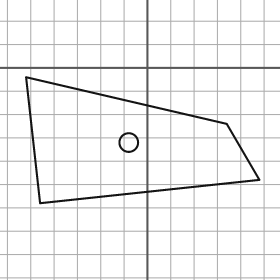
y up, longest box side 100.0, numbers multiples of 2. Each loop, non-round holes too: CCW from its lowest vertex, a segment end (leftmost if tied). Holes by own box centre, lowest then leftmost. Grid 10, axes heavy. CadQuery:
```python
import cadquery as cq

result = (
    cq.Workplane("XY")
    .moveTo(-46.0, -58.0)
    .lineTo(48.0, -48.0)
    .lineTo(34.0, -24.0)
    .lineTo(-52.0, -4.0)
    .close()
    .moveTo(-8.0, -32.0)
    .circle(4.0)
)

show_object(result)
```